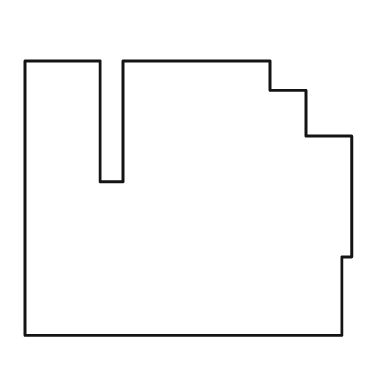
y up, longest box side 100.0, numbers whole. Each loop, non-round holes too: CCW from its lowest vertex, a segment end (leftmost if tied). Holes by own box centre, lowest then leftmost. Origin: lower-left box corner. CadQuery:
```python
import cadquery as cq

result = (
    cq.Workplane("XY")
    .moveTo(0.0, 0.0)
    .lineTo(97.0, 0.0)
    .lineTo(97.0, 24.0)
    .lineTo(100.0, 24.0)
    .lineTo(100.0, 61.0)
    .lineTo(86.0, 61.0)
    .lineTo(86.0, 75.0)
    .lineTo(75.0, 75.0)
    .lineTo(75.0, 84.0)
    .lineTo(30.0, 84.0)
    .lineTo(30.0, 47.0)
    .lineTo(23.0, 47.0)
    .lineTo(23.0, 84.0)
    .lineTo(0.0, 84.0)
    .close()
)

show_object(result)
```